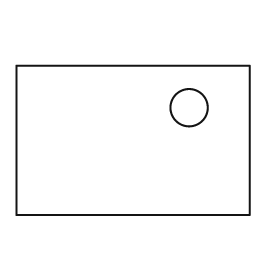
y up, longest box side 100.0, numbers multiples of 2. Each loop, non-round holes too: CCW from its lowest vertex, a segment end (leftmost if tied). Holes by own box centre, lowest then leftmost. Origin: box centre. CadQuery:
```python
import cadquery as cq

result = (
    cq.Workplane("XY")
    .moveTo(-50.0, -32.0)
    .lineTo(50.0, -32.0)
    .lineTo(50.0, 32.0)
    .lineTo(-50.0, 32.0)
    .close()
    .moveTo(24.0, 14.0)
    .circle(8.0)
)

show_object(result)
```